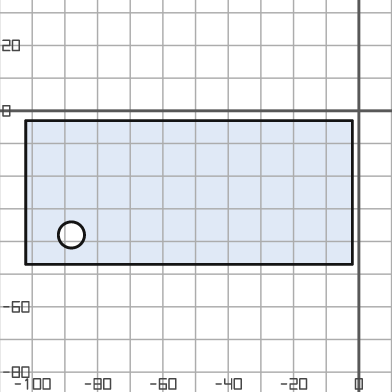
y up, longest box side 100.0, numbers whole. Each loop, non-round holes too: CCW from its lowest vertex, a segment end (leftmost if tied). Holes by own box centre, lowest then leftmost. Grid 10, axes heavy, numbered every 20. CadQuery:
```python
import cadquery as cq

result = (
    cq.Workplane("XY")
    .moveTo(-102.0, -47.0)
    .lineTo(-2.0, -47.0)
    .lineTo(-2.0, -3.0)
    .lineTo(-102.0, -3.0)
    .close()
    .moveTo(-88.0, -38.0)
    .circle(4.0)
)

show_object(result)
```